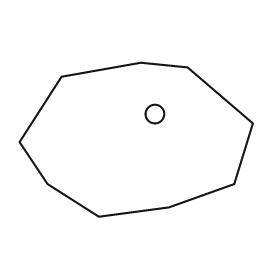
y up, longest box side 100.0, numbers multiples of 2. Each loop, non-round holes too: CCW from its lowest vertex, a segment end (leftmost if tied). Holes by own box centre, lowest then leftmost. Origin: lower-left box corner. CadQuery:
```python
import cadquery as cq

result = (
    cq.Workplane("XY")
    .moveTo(34.0, 0.0)
    .lineTo(64.0, 4.0)
    .lineTo(92.0, 14.0)
    .lineTo(100.0, 40.0)
    .lineTo(72.0, 64.0)
    .lineTo(52.0, 66.0)
    .lineTo(18.0, 60.0)
    .lineTo(0.0, 32.0)
    .lineTo(12.0, 14.0)
    .close()
    .moveTo(58.0, 44.0)
    .circle(4.0)
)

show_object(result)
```